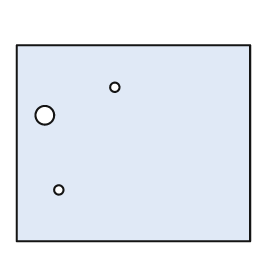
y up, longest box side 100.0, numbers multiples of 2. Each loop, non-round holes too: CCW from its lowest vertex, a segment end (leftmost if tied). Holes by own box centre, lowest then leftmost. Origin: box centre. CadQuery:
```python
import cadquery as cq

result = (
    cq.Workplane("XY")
    .moveTo(-50.0, -42.0)
    .lineTo(50.0, -42.0)
    .lineTo(50.0, 42.0)
    .lineTo(-50.0, 42.0)
    .close()
    .moveTo(-32.0, -20.0)
    .circle(2.0)
    .moveTo(-38.0, 12.0)
    .circle(4.0)
    .moveTo(-8.0, 24.0)
    .circle(2.0)
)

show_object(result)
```